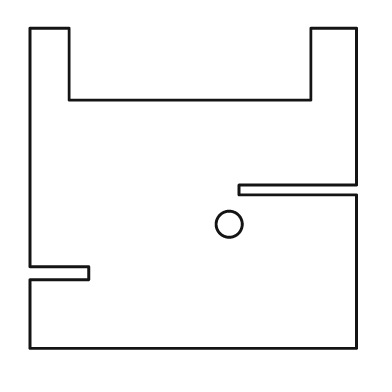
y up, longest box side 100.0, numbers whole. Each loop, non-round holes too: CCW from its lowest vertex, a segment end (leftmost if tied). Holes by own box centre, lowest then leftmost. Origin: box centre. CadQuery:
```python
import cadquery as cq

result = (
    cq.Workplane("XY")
    .moveTo(-50.0, -49.0)
    .lineTo(50.0, -49.0)
    .lineTo(50.0, -2.0)
    .lineTo(14.0, -2.0)
    .lineTo(14.0, 1.0)
    .lineTo(50.0, 1.0)
    .lineTo(50.0, 49.0)
    .lineTo(36.0, 49.0)
    .lineTo(36.0, 27.0)
    .lineTo(-38.0, 27.0)
    .lineTo(-38.0, 49.0)
    .lineTo(-50.0, 49.0)
    .lineTo(-50.0, -24.0)
    .lineTo(-32.0, -24.0)
    .lineTo(-32.0, -28.0)
    .lineTo(-50.0, -28.0)
    .close()
    .moveTo(11.0, -11.0)
    .circle(4.0)
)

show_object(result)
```